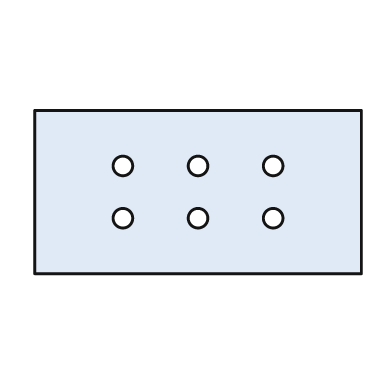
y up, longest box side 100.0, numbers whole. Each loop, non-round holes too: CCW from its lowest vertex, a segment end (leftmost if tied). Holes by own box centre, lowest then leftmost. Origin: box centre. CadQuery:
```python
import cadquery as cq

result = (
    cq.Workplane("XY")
    .moveTo(-50.0, -25.0)
    .lineTo(50.0, -25.0)
    .lineTo(50.0, 25.0)
    .lineTo(-50.0, 25.0)
    .close()
    .moveTo(-23.0, -8.0)
    .circle(3.0)
    .moveTo(0.0, -8.0)
    .circle(3.0)
    .moveTo(23.0, -8.0)
    .circle(3.0)
    .moveTo(-23.0, 8.0)
    .circle(3.0)
    .moveTo(0.0, 8.0)
    .circle(3.0)
    .moveTo(23.0, 8.0)
    .circle(3.0)
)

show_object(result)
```